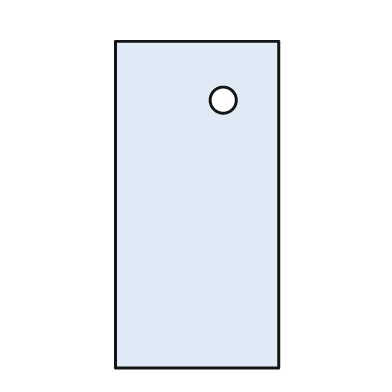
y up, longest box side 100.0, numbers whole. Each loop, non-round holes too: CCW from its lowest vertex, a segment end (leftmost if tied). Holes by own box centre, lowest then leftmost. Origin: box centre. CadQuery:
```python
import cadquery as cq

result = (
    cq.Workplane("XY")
    .moveTo(-25.0, -50.0)
    .lineTo(25.0, -50.0)
    .lineTo(25.0, 50.0)
    .lineTo(-25.0, 50.0)
    .close()
    .moveTo(8.0, 32.0)
    .circle(4.0)
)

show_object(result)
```